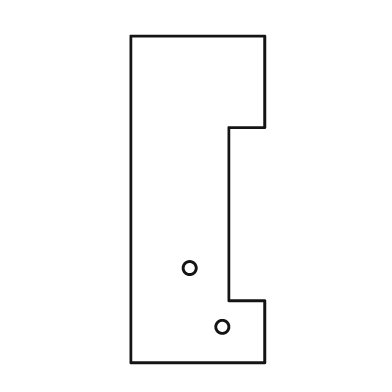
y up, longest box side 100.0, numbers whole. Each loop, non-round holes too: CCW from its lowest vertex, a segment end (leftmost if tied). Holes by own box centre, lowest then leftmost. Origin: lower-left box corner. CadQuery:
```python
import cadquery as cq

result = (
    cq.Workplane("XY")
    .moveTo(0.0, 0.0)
    .lineTo(41.0, 0.0)
    .lineTo(41.0, 19.0)
    .lineTo(30.0, 19.0)
    .lineTo(30.0, 72.0)
    .lineTo(41.0, 72.0)
    .lineTo(41.0, 100.0)
    .lineTo(0.0, 100.0)
    .close()
    .moveTo(28.0, 11.0)
    .circle(2.0)
    .moveTo(18.0, 29.0)
    .circle(2.0)
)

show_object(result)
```